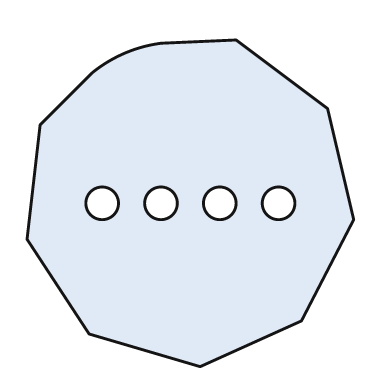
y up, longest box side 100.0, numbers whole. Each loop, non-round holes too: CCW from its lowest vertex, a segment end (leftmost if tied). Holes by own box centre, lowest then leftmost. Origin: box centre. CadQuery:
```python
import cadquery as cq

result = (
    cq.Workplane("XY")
    .moveTo(3.0, -50.0)
    .lineTo(34.0, -36.0)
    .lineTo(50.0, -5.0)
    .lineTo(42.0, 29.0)
    .lineTo(14.0, 50.0)
    .lineTo(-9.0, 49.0)
    .threePointArc((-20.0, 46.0), (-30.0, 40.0))
    .lineTo(-46.0, 24.0)
    .lineTo(-50.0, -11.0)
    .lineTo(-31.0, -40.0)
    .close()
    .moveTo(-27.0, 0.0)
    .circle(5.0)
    .moveTo(-9.0, 0.0)
    .circle(5.0)
    .moveTo(9.0, 0.0)
    .circle(5.0)
    .moveTo(27.0, 0.0)
    .circle(5.0)
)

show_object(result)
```